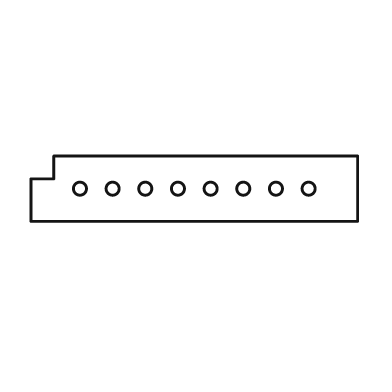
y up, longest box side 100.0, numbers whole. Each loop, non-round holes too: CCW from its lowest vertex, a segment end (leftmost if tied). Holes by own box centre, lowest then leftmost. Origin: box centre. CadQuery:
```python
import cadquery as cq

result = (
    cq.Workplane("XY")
    .moveTo(-50.0, -10.0)
    .lineTo(50.0, -10.0)
    .lineTo(50.0, 10.0)
    .lineTo(-43.0, 10.0)
    .lineTo(-43.0, 3.0)
    .lineTo(-50.0, 3.0)
    .close()
    .moveTo(-35.0, 0.0)
    .circle(2.0)
    .moveTo(-25.0, 0.0)
    .circle(2.0)
    .moveTo(-15.0, 0.0)
    .circle(2.0)
    .moveTo(-5.0, 0.0)
    .circle(2.0)
    .moveTo(5.0, 0.0)
    .circle(2.0)
    .moveTo(15.0, 0.0)
    .circle(2.0)
    .moveTo(25.0, 0.0)
    .circle(2.0)
    .moveTo(35.0, 0.0)
    .circle(2.0)
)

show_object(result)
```